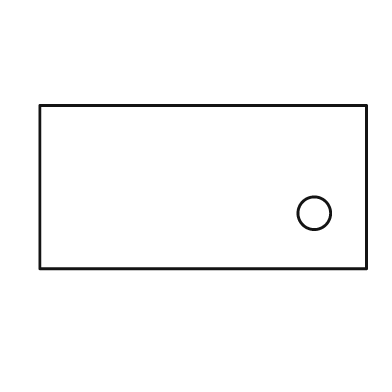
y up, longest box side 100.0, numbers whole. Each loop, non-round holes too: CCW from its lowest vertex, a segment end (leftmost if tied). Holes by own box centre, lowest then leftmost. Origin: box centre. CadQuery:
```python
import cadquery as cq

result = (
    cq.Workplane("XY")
    .moveTo(-50.0, -25.0)
    .lineTo(50.0, -25.0)
    .lineTo(50.0, 25.0)
    .lineTo(-50.0, 25.0)
    .close()
    .moveTo(34.0, -8.0)
    .circle(5.0)
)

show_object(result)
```